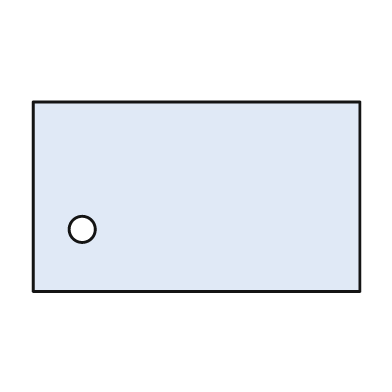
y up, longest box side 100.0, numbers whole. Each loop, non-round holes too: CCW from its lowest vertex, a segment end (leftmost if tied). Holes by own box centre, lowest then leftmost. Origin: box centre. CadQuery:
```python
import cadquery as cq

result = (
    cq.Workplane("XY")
    .moveTo(-50.0, -29.0)
    .lineTo(50.0, -29.0)
    .lineTo(50.0, 29.0)
    .lineTo(-50.0, 29.0)
    .close()
    .moveTo(-35.0, -10.0)
    .circle(4.0)
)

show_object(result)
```